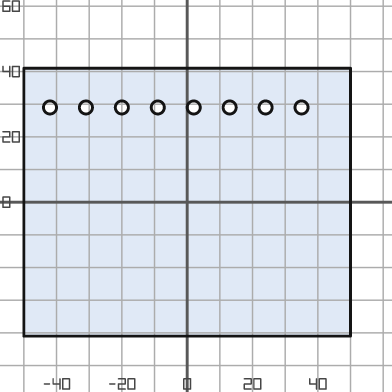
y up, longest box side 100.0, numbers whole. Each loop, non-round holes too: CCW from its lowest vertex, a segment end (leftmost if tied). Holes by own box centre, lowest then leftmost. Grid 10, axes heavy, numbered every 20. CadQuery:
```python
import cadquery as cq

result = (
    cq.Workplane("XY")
    .moveTo(-50.0, -41.0)
    .lineTo(50.0, -41.0)
    .lineTo(50.0, 41.0)
    .lineTo(-50.0, 41.0)
    .close()
    .moveTo(-42.0, 29.0)
    .circle(2.0)
    .moveTo(-31.0, 29.0)
    .circle(2.0)
    .moveTo(-20.0, 29.0)
    .circle(2.0)
    .moveTo(-9.0, 29.0)
    .circle(2.0)
    .moveTo(2.0, 29.0)
    .circle(2.0)
    .moveTo(13.0, 29.0)
    .circle(2.0)
    .moveTo(24.0, 29.0)
    .circle(2.0)
    .moveTo(35.0, 29.0)
    .circle(2.0)
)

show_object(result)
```